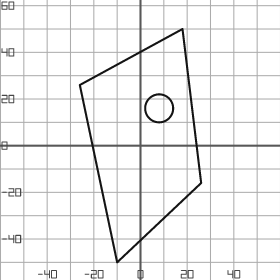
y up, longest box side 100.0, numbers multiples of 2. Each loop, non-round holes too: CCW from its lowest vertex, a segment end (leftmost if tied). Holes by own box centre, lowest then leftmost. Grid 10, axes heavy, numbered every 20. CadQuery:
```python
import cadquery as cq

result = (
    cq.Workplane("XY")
    .moveTo(-10.0, -50.0)
    .lineTo(26.0, -16.0)
    .lineTo(18.0, 50.0)
    .lineTo(-26.0, 26.0)
    .close()
    .moveTo(8.0, 16.0)
    .circle(6.0)
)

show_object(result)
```